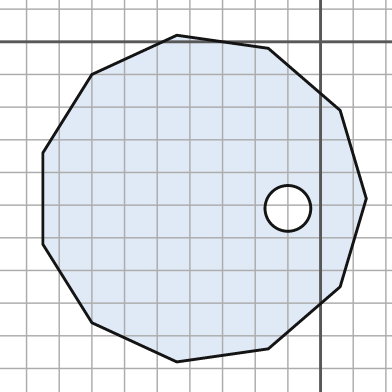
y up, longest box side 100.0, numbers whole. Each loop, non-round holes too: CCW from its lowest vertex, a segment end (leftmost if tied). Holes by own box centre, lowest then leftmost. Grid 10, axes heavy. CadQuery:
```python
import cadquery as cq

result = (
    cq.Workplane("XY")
    .moveTo(-44.0, -98.0)
    .lineTo(-16.0, -94.0)
    .lineTo(6.0, -75.0)
    .lineTo(14.0, -48.0)
    .lineTo(6.0, -21.0)
    .lineTo(-16.0, -2.0)
    .lineTo(-44.0, 2.0)
    .lineTo(-70.0, -10.0)
    .lineTo(-85.0, -34.0)
    .lineTo(-85.0, -62.0)
    .lineTo(-70.0, -86.0)
    .close()
    .moveTo(-10.0, -51.0)
    .circle(7.0)
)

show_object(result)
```